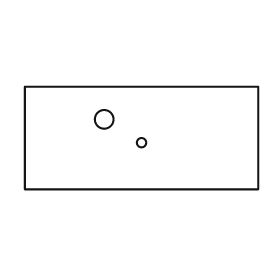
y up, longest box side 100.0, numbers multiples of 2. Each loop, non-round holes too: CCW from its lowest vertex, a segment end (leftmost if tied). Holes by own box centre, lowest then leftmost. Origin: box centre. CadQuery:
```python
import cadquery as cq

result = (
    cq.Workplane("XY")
    .moveTo(-50.0, -22.0)
    .lineTo(50.0, -22.0)
    .lineTo(50.0, 22.0)
    .lineTo(-50.0, 22.0)
    .close()
    .moveTo(0.0, -2.0)
    .circle(2.0)
    .moveTo(-16.0, 8.0)
    .circle(4.0)
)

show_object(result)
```